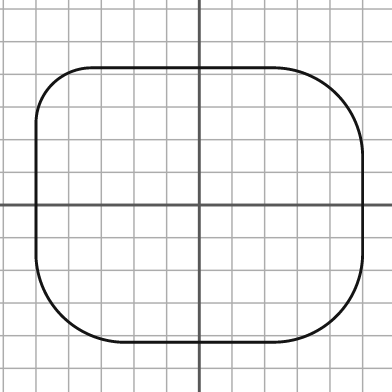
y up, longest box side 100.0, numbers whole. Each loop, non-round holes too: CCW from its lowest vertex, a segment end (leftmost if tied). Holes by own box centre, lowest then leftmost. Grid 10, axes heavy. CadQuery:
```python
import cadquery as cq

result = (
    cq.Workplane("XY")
    .moveTo(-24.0, -42.0)
    .lineTo(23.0, -42.0)
    .threePointArc((42.0, -34.0), (50.0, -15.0))
    .lineTo(50.0, 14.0)
    .threePointArc((42.0, 34.0), (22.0, 42.0))
    .lineTo(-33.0, 42.0)
    .threePointArc((-45.0, 37.0), (-50.0, 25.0))
    .lineTo(-50.0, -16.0)
    .threePointArc((-42.0, -34.0), (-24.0, -42.0))
    .close()
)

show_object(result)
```